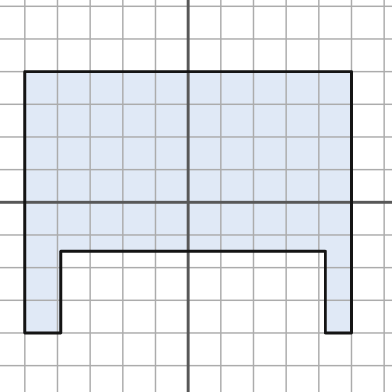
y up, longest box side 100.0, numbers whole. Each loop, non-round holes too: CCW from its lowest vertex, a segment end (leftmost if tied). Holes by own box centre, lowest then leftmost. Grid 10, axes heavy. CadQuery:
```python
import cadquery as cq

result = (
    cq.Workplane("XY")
    .moveTo(-50.0, -40.0)
    .lineTo(-39.0, -40.0)
    .lineTo(-39.0, -15.0)
    .lineTo(42.0, -15.0)
    .lineTo(42.0, -40.0)
    .lineTo(50.0, -40.0)
    .lineTo(50.0, 40.0)
    .lineTo(-50.0, 40.0)
    .close()
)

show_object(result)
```